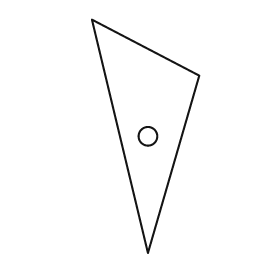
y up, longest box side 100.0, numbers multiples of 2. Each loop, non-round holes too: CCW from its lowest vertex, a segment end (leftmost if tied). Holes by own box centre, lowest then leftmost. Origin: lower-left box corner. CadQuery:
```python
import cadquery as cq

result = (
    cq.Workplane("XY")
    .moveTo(24.0, 0.0)
    .lineTo(46.0, 76.0)
    .lineTo(0.0, 100.0)
    .close()
    .moveTo(24.0, 50.0)
    .circle(4.0)
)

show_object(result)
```